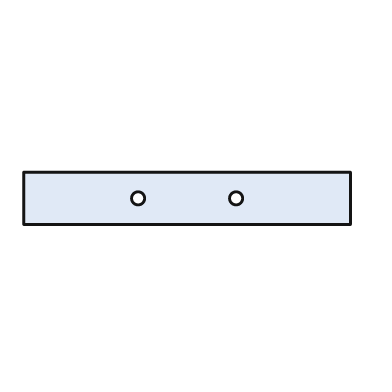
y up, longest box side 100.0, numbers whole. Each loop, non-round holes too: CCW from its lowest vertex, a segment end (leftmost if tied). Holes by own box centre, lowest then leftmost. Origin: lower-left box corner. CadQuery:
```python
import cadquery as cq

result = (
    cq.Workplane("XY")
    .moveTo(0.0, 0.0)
    .lineTo(100.0, 0.0)
    .lineTo(100.0, 16.0)
    .lineTo(0.0, 16.0)
    .close()
    .moveTo(35.0, 8.0)
    .circle(2.0)
    .moveTo(65.0, 8.0)
    .circle(2.0)
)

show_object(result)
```